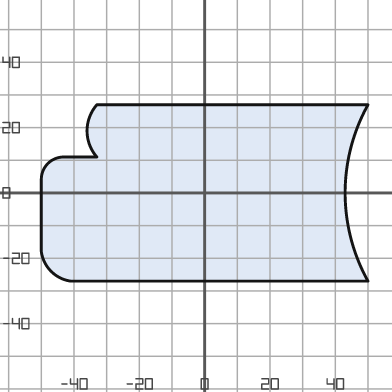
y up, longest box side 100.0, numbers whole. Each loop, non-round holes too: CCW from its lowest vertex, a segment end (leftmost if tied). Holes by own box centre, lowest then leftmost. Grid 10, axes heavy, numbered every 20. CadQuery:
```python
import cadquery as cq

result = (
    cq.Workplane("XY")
    .moveTo(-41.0, -27.0)
    .lineTo(50.0, -27.0)
    .threePointArc((43.0, 0.0), (50.0, 27.0))
    .lineTo(-33.0, 27.0)
    .threePointArc((-36.0, 19.0), (-33.0, 11.0))
    .lineTo(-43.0, 11.0)
    .threePointArc((-48.0, 9.0), (-50.0, 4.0))
    .lineTo(-50.0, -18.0)
    .threePointArc((-47.0, -24.0), (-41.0, -27.0))
    .close()
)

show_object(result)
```